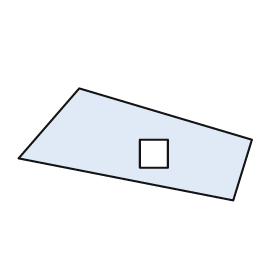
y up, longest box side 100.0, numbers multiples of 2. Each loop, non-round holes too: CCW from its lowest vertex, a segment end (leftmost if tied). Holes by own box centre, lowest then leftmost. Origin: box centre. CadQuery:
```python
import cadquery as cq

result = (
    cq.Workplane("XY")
    .moveTo(42.0, -24.0)
    .lineTo(50.0, 2.0)
    .lineTo(-24.0, 24.0)
    .lineTo(-50.0, -6.0)
    .close()
    .moveTo(2.0, -10.0)
    .lineTo(14.0, -10.0)
    .lineTo(14.0, 2.0)
    .lineTo(2.0, 2.0)
    .close()
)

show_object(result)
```